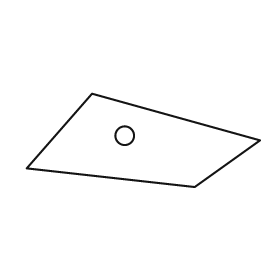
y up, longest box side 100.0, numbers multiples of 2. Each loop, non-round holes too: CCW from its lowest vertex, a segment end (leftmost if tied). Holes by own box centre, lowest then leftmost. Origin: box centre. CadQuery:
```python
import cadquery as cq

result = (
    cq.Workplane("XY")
    .moveTo(22.0, -20.0)
    .lineTo(50.0, 0.0)
    .lineTo(-22.0, 20.0)
    .lineTo(-50.0, -12.0)
    .close()
    .moveTo(-8.0, 2.0)
    .circle(4.0)
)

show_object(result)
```